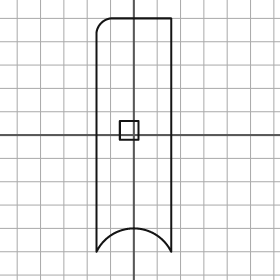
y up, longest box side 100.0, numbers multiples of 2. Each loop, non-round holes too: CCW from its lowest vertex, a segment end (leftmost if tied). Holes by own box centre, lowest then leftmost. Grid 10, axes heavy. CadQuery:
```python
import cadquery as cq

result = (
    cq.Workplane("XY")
    .moveTo(-16.0, -50.0)
    .threePointArc((0.0, -40.0), (16.0, -50.0))
    .lineTo(16.0, 50.0)
    .lineTo(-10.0, 50.0)
    .threePointArc((-14.0, 48.0), (-16.0, 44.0))
    .close()
    .moveTo(-6.0, -2.0)
    .lineTo(2.0, -2.0)
    .lineTo(2.0, 6.0)
    .lineTo(-6.0, 6.0)
    .close()
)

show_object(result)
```